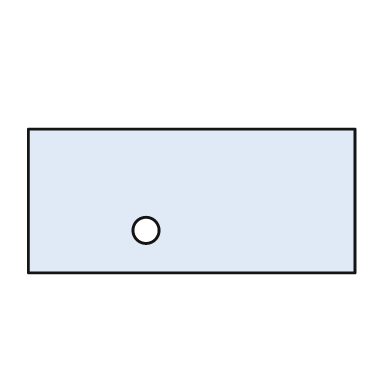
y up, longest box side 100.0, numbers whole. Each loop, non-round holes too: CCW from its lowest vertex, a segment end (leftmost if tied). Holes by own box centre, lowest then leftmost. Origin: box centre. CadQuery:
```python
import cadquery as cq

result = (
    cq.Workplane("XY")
    .moveTo(-50.0, -22.0)
    .lineTo(50.0, -22.0)
    .lineTo(50.0, 22.0)
    .lineTo(-50.0, 22.0)
    .close()
    .moveTo(-14.0, -9.0)
    .circle(4.0)
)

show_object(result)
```